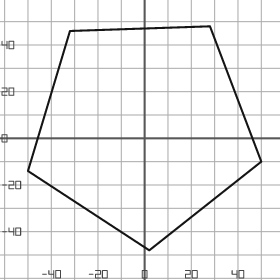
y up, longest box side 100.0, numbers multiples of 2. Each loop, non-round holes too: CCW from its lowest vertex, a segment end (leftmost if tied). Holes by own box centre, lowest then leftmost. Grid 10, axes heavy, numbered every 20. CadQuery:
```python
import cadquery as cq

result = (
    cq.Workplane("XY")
    .moveTo(2.0, -48.0)
    .lineTo(50.0, -10.0)
    .lineTo(28.0, 48.0)
    .lineTo(-32.0, 46.0)
    .lineTo(-50.0, -14.0)
    .close()
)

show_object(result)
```